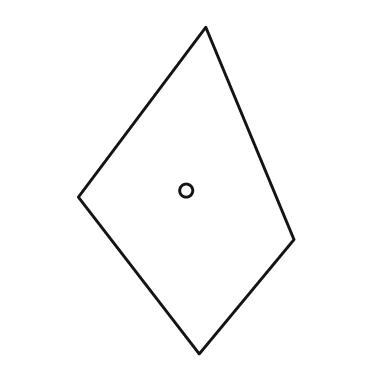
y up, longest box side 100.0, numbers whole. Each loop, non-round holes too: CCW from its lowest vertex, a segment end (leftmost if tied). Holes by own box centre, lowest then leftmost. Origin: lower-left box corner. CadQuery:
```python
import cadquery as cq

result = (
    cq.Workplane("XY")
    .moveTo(37.0, 0.0)
    .lineTo(66.0, 35.0)
    .lineTo(39.0, 100.0)
    .lineTo(0.0, 48.0)
    .close()
    .moveTo(33.0, 50.0)
    .circle(2.0)
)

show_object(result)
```